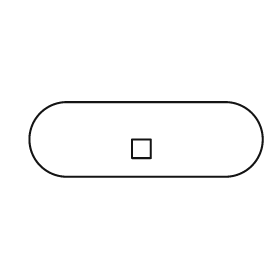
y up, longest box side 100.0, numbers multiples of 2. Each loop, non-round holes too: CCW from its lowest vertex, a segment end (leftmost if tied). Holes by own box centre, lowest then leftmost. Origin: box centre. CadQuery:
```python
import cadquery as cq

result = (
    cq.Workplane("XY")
    .moveTo(-34.0, -16.0)
    .lineTo(34.0, -16.0)
    .threePointArc((50.0, 0.0), (34.0, 16.0))
    .lineTo(-34.0, 16.0)
    .threePointArc((-50.0, 0.0), (-34.0, -16.0))
    .close()
    .moveTo(-6.0, -8.0)
    .lineTo(2.0, -8.0)
    .lineTo(2.0, 0.0)
    .lineTo(-6.0, 0.0)
    .close()
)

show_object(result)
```